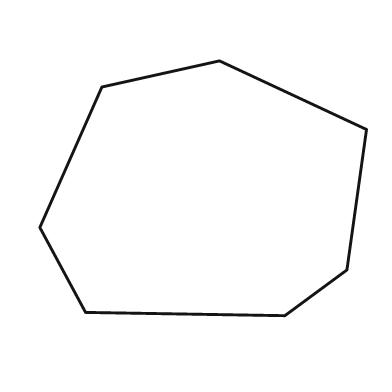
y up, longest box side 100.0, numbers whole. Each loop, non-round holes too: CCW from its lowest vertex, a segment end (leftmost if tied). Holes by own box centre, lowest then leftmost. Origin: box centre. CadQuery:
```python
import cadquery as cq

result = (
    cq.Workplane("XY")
    .moveTo(25.0, -39.0)
    .lineTo(44.0, -25.0)
    .lineTo(50.0, 18.0)
    .lineTo(5.0, 39.0)
    .lineTo(-31.0, 31.0)
    .lineTo(-50.0, -12.0)
    .lineTo(-36.0, -38.0)
    .close()
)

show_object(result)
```